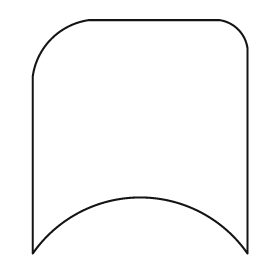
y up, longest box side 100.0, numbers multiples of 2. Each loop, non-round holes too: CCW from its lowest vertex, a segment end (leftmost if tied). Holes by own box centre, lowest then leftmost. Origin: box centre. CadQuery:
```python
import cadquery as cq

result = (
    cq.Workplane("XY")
    .moveTo(-46.0, -50.0)
    .threePointArc((0.0, -26.0), (46.0, -50.0))
    .lineTo(46.0, 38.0)
    .threePointArc((42.0, 46.0), (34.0, 50.0))
    .lineTo(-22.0, 50.0)
    .threePointArc((-38.0, 42.0), (-46.0, 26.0))
    .close()
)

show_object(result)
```